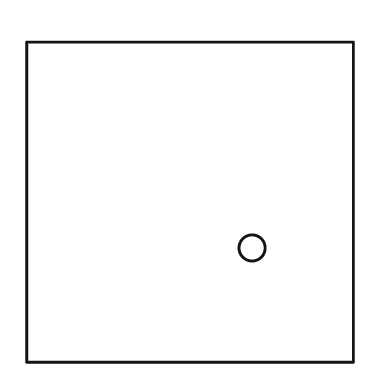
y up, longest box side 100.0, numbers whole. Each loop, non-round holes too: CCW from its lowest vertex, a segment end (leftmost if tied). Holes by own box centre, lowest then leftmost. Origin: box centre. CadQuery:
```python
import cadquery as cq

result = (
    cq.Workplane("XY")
    .moveTo(-50.0, -49.0)
    .lineTo(50.0, -49.0)
    .lineTo(50.0, 49.0)
    .lineTo(-50.0, 49.0)
    .close()
    .moveTo(19.0, -14.0)
    .circle(4.0)
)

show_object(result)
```